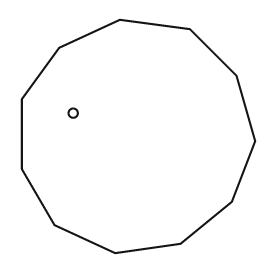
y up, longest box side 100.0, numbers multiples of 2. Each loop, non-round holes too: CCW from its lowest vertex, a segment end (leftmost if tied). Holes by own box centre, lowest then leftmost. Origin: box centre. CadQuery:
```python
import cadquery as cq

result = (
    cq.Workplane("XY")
    .moveTo(-10.0, -50.0)
    .lineTo(18.0, -46.0)
    .lineTo(40.0, -28.0)
    .lineTo(50.0, -2.0)
    .lineTo(42.0, 26.0)
    .lineTo(22.0, 46.0)
    .lineTo(-8.0, 50.0)
    .lineTo(-34.0, 38.0)
    .lineTo(-50.0, 16.0)
    .lineTo(-50.0, -14.0)
    .lineTo(-36.0, -38.0)
    .close()
    .moveTo(-28.0, 10.0)
    .circle(2.0)
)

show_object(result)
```